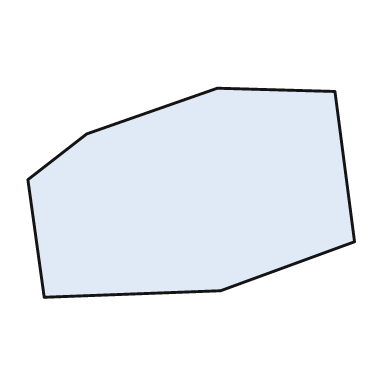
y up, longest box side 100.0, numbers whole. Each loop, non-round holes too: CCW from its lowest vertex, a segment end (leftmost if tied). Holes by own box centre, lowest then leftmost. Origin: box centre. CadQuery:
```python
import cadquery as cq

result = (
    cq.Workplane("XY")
    .moveTo(-45.0, -32.0)
    .lineTo(9.0, -30.0)
    .lineTo(50.0, -15.0)
    .lineTo(44.0, 31.0)
    .lineTo(8.0, 32.0)
    .lineTo(-32.0, 18.0)
    .lineTo(-50.0, 4.0)
    .close()
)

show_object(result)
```